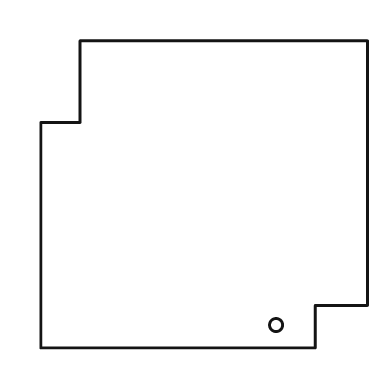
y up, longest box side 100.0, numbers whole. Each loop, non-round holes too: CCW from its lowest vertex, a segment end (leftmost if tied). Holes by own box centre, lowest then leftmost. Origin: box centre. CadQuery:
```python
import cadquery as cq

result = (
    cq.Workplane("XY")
    .moveTo(-50.0, -47.0)
    .lineTo(34.0, -47.0)
    .lineTo(34.0, -34.0)
    .lineTo(50.0, -34.0)
    .lineTo(50.0, 47.0)
    .lineTo(-38.0, 47.0)
    .lineTo(-38.0, 22.0)
    .lineTo(-50.0, 22.0)
    .close()
    .moveTo(22.0, -40.0)
    .circle(2.0)
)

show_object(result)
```